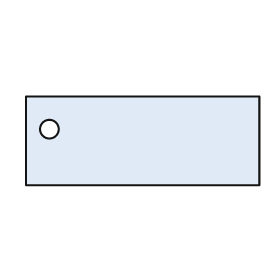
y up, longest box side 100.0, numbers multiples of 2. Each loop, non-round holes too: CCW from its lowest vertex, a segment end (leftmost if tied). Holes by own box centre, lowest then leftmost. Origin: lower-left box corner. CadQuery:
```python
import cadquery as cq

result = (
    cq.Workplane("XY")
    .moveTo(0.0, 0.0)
    .lineTo(100.0, 0.0)
    .lineTo(100.0, 38.0)
    .lineTo(0.0, 38.0)
    .close()
    .moveTo(10.0, 24.0)
    .circle(4.0)
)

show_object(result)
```